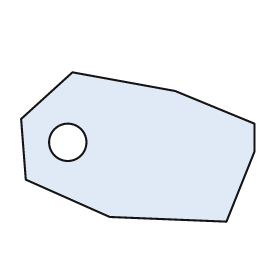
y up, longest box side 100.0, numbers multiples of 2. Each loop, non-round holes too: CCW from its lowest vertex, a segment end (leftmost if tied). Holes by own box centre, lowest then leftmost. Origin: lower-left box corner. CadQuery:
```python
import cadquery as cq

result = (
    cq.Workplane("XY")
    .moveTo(88.0, 0.0)
    .lineTo(100.0, 30.0)
    .lineTo(100.0, 42.0)
    .lineTo(66.0, 56.0)
    .lineTo(22.0, 64.0)
    .lineTo(0.0, 44.0)
    .lineTo(2.0, 18.0)
    .lineTo(38.0, 2.0)
    .close()
    .moveTo(20.0, 34.0)
    .circle(8.0)
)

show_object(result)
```